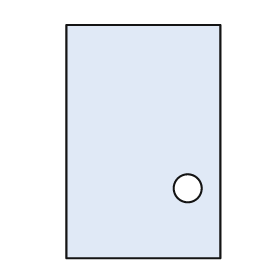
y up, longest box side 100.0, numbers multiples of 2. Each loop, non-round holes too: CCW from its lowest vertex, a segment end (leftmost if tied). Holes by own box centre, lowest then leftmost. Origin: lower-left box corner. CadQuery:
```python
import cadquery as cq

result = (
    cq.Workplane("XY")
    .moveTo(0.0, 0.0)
    .lineTo(66.0, 0.0)
    .lineTo(66.0, 100.0)
    .lineTo(0.0, 100.0)
    .close()
    .moveTo(52.0, 30.0)
    .circle(6.0)
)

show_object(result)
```